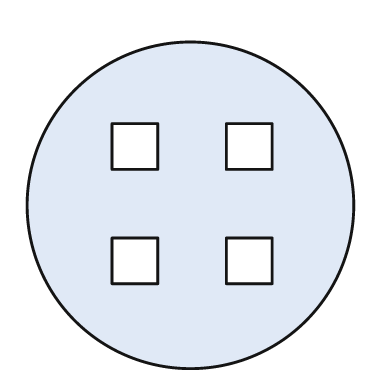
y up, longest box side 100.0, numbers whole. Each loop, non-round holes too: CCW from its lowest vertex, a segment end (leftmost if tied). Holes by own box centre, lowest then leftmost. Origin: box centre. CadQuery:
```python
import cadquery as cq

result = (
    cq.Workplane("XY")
    .moveTo(0.0, 0.0)
    .circle(50.0)
    .moveTo(-24.0, -24.0)
    .lineTo(-10.0, -24.0)
    .lineTo(-10.0, -10.0)
    .lineTo(-24.0, -10.0)
    .close()
    .moveTo(11.0, -24.0)
    .lineTo(25.0, -24.0)
    .lineTo(25.0, -10.0)
    .lineTo(11.0, -10.0)
    .close()
    .moveTo(-24.0, 11.0)
    .lineTo(-10.0, 11.0)
    .lineTo(-10.0, 25.0)
    .lineTo(-24.0, 25.0)
    .close()
    .moveTo(11.0, 11.0)
    .lineTo(25.0, 11.0)
    .lineTo(25.0, 25.0)
    .lineTo(11.0, 25.0)
    .close()
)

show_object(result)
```